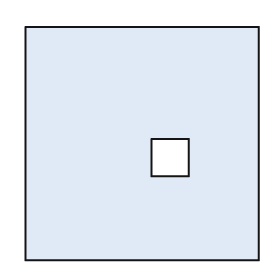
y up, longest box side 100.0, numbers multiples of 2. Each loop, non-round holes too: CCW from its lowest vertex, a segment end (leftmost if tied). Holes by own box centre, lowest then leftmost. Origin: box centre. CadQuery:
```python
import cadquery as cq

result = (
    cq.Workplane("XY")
    .moveTo(-50.0, -50.0)
    .lineTo(50.0, -50.0)
    .lineTo(50.0, 50.0)
    .lineTo(-50.0, 50.0)
    .close()
    .moveTo(4.0, -14.0)
    .lineTo(20.0, -14.0)
    .lineTo(20.0, 2.0)
    .lineTo(4.0, 2.0)
    .close()
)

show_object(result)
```